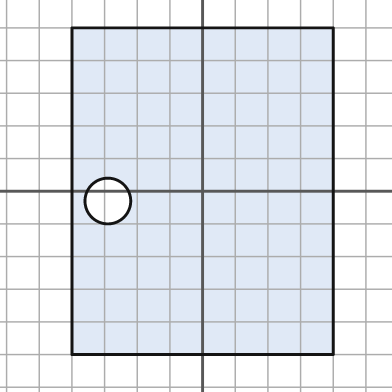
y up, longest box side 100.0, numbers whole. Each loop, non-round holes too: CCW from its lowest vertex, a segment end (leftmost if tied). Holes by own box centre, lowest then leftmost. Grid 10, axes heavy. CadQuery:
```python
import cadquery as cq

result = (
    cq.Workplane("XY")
    .moveTo(-40.0, -50.0)
    .lineTo(40.0, -50.0)
    .lineTo(40.0, 50.0)
    .lineTo(-40.0, 50.0)
    .close()
    .moveTo(-29.0, -3.0)
    .circle(7.0)
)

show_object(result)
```